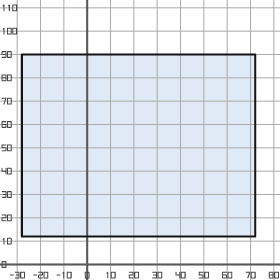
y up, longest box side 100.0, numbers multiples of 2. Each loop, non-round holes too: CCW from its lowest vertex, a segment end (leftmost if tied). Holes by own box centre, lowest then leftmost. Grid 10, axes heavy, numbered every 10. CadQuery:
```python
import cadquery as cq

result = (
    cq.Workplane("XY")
    .moveTo(-28.0, 12.0)
    .lineTo(72.0, 12.0)
    .lineTo(72.0, 90.0)
    .lineTo(-28.0, 90.0)
    .close()
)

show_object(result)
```